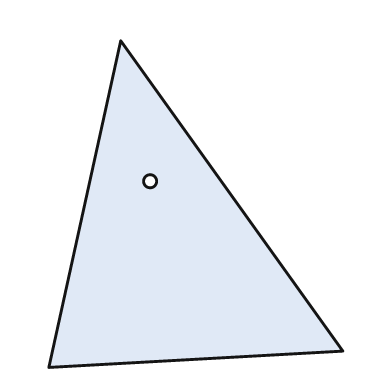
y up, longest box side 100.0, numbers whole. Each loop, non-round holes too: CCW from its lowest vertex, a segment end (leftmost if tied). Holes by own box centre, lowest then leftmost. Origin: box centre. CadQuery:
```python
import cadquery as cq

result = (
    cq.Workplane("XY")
    .moveTo(-45.0, -50.0)
    .lineTo(45.0, -45.0)
    .lineTo(-23.0, 50.0)
    .close()
    .moveTo(-14.0, 7.0)
    .circle(2.0)
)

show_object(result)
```